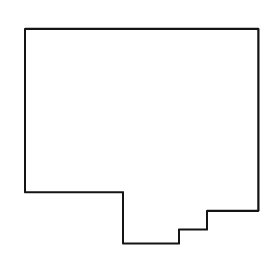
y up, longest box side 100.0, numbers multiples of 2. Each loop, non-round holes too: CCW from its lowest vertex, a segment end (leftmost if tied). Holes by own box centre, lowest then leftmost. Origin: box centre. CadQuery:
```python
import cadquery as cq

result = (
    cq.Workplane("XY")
    .moveTo(-8.0, -46.0)
    .lineTo(16.0, -46.0)
    .lineTo(16.0, -40.0)
    .lineTo(28.0, -40.0)
    .lineTo(28.0, -32.0)
    .lineTo(50.0, -32.0)
    .lineTo(50.0, 46.0)
    .lineTo(-50.0, 46.0)
    .lineTo(-50.0, -24.0)
    .lineTo(-8.0, -24.0)
    .close()
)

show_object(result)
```